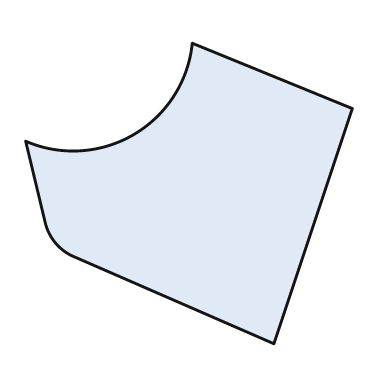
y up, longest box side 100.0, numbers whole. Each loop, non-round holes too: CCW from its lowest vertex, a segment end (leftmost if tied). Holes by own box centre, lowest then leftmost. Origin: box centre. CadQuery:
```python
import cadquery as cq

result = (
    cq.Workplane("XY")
    .moveTo(26.0, -46.0)
    .lineTo(50.0, 26.0)
    .lineTo(1.0, 46.0)
    .threePointArc((-17.0, 18.0), (-50.0, 16.0))
    .lineTo(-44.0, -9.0)
    .threePointArc((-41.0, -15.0), (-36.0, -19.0))
    .close()
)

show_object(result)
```